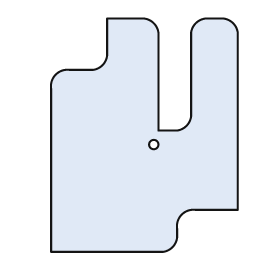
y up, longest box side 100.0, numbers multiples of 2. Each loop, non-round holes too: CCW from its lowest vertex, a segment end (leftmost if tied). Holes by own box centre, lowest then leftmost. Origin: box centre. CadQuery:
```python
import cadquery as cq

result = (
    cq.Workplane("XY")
    .moveTo(-40.0, -50.0)
    .lineTo(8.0, -50.0)
    .threePointArc((12.0, -48.0), (14.0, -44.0))
    .lineTo(14.0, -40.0)
    .threePointArc((16.0, -34.0), (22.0, -32.0))
    .lineTo(40.0, -32.0)
    .lineTo(40.0, 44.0)
    .threePointArc((38.0, 48.0), (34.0, 50.0))
    .lineTo(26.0, 50.0)
    .threePointArc((22.0, 48.0), (20.0, 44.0))
    .lineTo(20.0, 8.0)
    .threePointArc((18.0, 4.0), (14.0, 2.0))
    .lineTo(6.0, 2.0)
    .lineTo(6.0, 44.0)
    .threePointArc((4.0, 48.0), (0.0, 50.0))
    .lineTo(-16.0, 50.0)
    .lineTo(-16.0, 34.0)
    .threePointArc((-18.0, 30.0), (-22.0, 28.0))
    .lineTo(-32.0, 28.0)
    .threePointArc((-38.0, 26.0), (-40.0, 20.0))
    .close()
    .moveTo(4.0, -4.0)
    .circle(2.0)
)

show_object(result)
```